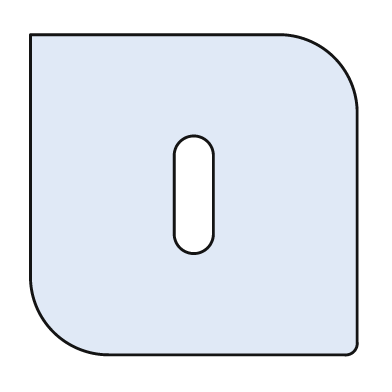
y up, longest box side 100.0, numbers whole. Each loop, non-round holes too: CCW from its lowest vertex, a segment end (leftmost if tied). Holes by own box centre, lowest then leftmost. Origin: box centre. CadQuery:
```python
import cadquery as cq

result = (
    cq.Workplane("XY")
    .moveTo(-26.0, -49.0)
    .lineTo(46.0, -49.0)
    .threePointArc((49.0, -48.0), (50.0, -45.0))
    .lineTo(50.0, 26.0)
    .threePointArc((43.0, 42.0), (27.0, 49.0))
    .lineTo(-50.0, 49.0)
    .lineTo(-50.0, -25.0)
    .threePointArc((-43.0, -42.0), (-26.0, -49.0))
    .close()
    .moveTo(-6.0, -12.0)
    .threePointArc((0.0, -18.0), (6.0, -12.0))
    .lineTo(6.0, 12.0)
    .threePointArc((0.0, 18.0), (-6.0, 12.0))
    .close()
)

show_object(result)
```